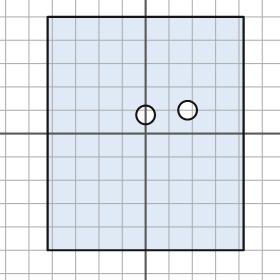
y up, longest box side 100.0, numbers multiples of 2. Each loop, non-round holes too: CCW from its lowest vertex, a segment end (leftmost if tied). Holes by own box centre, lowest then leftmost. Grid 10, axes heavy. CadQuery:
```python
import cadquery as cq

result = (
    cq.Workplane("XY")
    .moveTo(-42.0, -50.0)
    .lineTo(42.0, -50.0)
    .lineTo(42.0, 50.0)
    .lineTo(-42.0, 50.0)
    .close()
    .moveTo(0.0, 8.0)
    .circle(4.0)
    .moveTo(18.0, 10.0)
    .circle(4.0)
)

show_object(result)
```